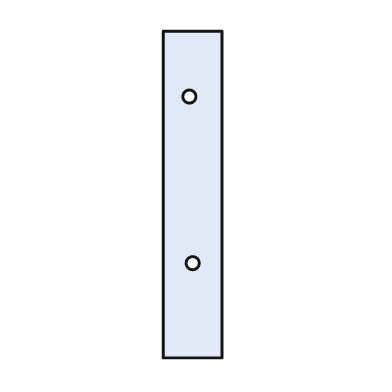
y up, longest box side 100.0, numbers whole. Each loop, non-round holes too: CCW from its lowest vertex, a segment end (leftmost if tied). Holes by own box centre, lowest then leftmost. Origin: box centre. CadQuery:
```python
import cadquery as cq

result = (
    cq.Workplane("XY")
    .moveTo(-9.0, -50.0)
    .lineTo(9.0, -50.0)
    .lineTo(9.0, 50.0)
    .lineTo(-9.0, 50.0)
    .close()
    .moveTo(0.0, -21.0)
    .circle(2.0)
    .moveTo(-1.0, 30.0)
    .circle(2.0)
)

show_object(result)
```